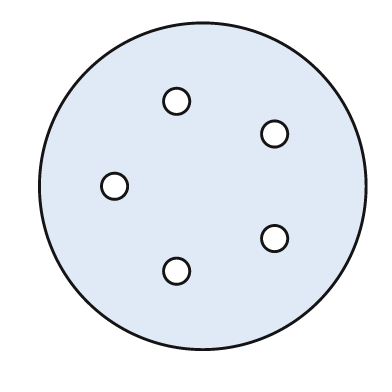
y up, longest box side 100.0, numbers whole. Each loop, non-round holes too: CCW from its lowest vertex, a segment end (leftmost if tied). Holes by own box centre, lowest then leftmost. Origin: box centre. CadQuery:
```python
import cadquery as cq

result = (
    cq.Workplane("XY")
    .moveTo(0.0, 0.0)
    .circle(50.0)
    .moveTo(-8.0, -26.0)
    .circle(4.0)
    .moveTo(22.0, -16.0)
    .circle(4.0)
    .moveTo(-27.0, 0.0)
    .circle(4.0)
    .moveTo(22.0, 16.0)
    .circle(4.0)
    .moveTo(-8.0, 26.0)
    .circle(4.0)
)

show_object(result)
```